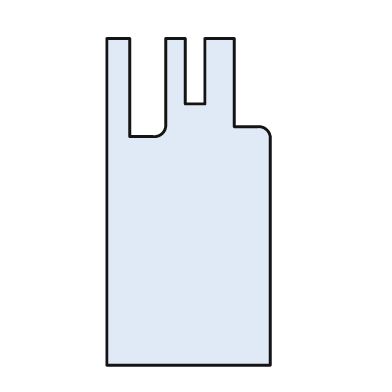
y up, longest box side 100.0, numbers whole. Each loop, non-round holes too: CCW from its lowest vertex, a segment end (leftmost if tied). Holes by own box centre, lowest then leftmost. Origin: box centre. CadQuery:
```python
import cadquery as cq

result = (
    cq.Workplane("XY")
    .moveTo(-25.0, -50.0)
    .lineTo(25.0, -50.0)
    .lineTo(25.0, 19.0)
    .threePointArc((24.0, 22.0), (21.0, 23.0))
    .lineTo(14.0, 23.0)
    .lineTo(14.0, 50.0)
    .lineTo(5.0, 50.0)
    .lineTo(5.0, 30.0)
    .lineTo(-1.0, 30.0)
    .lineTo(-1.0, 50.0)
    .lineTo(-7.0, 50.0)
    .lineTo(-7.0, 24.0)
    .threePointArc((-8.0, 21.0), (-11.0, 20.0))
    .lineTo(-18.0, 20.0)
    .lineTo(-18.0, 50.0)
    .lineTo(-25.0, 50.0)
    .close()
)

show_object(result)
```